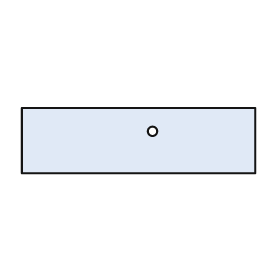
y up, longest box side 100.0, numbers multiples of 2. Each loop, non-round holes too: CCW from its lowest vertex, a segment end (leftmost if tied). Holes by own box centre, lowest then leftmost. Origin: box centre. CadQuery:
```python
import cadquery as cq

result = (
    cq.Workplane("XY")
    .moveTo(-50.0, -14.0)
    .lineTo(50.0, -14.0)
    .lineTo(50.0, 14.0)
    .lineTo(-50.0, 14.0)
    .close()
    .moveTo(6.0, 4.0)
    .circle(2.0)
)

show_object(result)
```